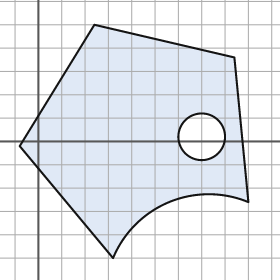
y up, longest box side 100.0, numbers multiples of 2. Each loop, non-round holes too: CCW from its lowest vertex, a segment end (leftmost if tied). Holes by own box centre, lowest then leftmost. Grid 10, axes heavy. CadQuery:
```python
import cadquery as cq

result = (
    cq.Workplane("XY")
    .moveTo(32.0, -50.0)
    .threePointArc((56.0, -26.0), (90.0, -26.0))
    .lineTo(84.0, 36.0)
    .lineTo(24.0, 50.0)
    .lineTo(-8.0, -2.0)
    .close()
    .moveTo(70.0, 2.0)
    .circle(10.0)
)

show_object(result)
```